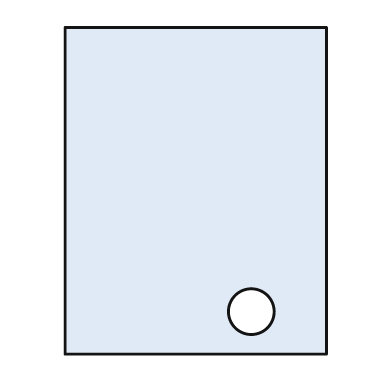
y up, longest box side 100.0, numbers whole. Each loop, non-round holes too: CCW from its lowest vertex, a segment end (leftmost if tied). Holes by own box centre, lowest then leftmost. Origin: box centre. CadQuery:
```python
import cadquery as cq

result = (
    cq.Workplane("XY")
    .moveTo(-40.0, -50.0)
    .lineTo(40.0, -50.0)
    .lineTo(40.0, 50.0)
    .lineTo(-40.0, 50.0)
    .close()
    .moveTo(17.0, -37.0)
    .circle(7.0)
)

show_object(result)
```